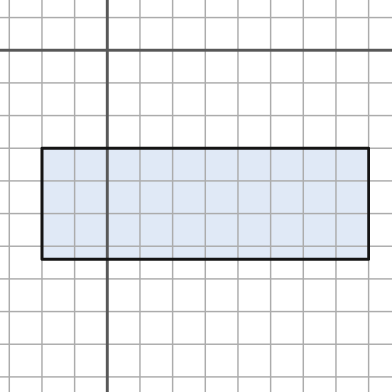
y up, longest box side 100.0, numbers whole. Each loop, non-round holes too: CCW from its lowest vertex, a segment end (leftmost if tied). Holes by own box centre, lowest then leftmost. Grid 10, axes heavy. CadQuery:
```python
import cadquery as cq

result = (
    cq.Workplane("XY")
    .moveTo(-20.0, -64.0)
    .lineTo(80.0, -64.0)
    .lineTo(80.0, -30.0)
    .lineTo(-20.0, -30.0)
    .close()
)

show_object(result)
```